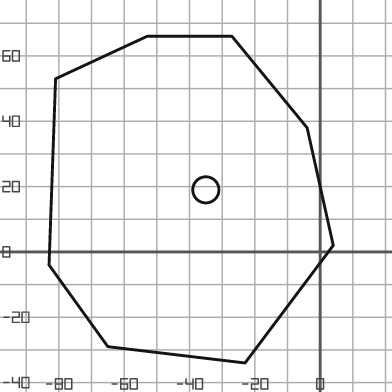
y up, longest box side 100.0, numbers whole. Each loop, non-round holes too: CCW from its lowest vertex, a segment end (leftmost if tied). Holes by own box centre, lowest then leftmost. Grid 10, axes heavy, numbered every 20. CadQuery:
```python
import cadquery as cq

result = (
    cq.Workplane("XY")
    .moveTo(-23.0, -34.0)
    .lineTo(4.0, 2.0)
    .lineTo(-4.0, 38.0)
    .lineTo(-27.0, 66.0)
    .lineTo(-53.0, 66.0)
    .lineTo(-81.0, 53.0)
    .lineTo(-83.0, -4.0)
    .lineTo(-65.0, -29.0)
    .close()
    .moveTo(-35.0, 19.0)
    .circle(4.0)
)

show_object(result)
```